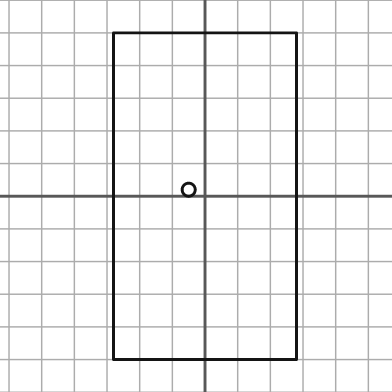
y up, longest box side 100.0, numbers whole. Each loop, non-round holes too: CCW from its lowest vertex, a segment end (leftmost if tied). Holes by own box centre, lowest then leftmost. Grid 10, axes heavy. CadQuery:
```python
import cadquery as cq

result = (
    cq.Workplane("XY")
    .moveTo(-28.0, -50.0)
    .lineTo(28.0, -50.0)
    .lineTo(28.0, 50.0)
    .lineTo(-28.0, 50.0)
    .close()
    .moveTo(-5.0, 2.0)
    .circle(2.0)
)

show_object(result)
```